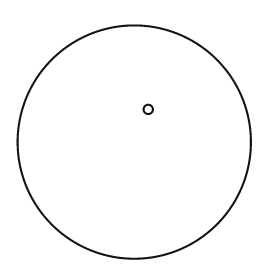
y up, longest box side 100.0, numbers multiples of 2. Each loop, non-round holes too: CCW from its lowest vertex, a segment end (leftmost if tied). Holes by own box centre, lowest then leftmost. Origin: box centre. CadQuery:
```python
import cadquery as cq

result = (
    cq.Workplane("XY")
    .moveTo(0.0, 0.0)
    .circle(50.0)
    .moveTo(6.0, 14.0)
    .circle(2.0)
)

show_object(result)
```